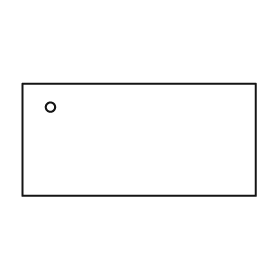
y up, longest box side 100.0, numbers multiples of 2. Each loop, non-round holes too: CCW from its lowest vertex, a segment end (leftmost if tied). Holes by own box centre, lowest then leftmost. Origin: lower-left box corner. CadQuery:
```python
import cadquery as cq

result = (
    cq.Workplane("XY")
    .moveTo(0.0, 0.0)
    .lineTo(100.0, 0.0)
    .lineTo(100.0, 48.0)
    .lineTo(0.0, 48.0)
    .close()
    .moveTo(12.0, 38.0)
    .circle(2.0)
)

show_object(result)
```